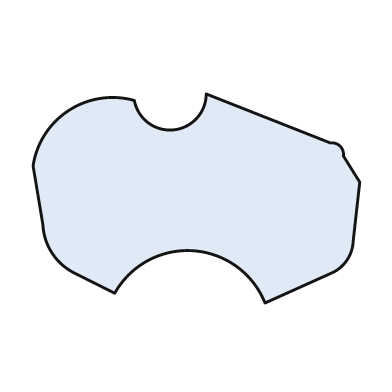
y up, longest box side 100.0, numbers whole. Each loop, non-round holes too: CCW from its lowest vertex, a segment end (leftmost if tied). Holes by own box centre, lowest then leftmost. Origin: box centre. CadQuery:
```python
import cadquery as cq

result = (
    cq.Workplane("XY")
    .moveTo(21.0, -32.0)
    .lineTo(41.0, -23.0)
    .threePointArc((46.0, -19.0), (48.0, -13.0))
    .lineTo(50.0, 5.0)
    .lineTo(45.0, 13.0)
    .threePointArc((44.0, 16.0), (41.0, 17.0))
    .lineTo(3.0, 32.0)
    .threePointArc((-7.0, 21.0), (-19.0, 30.0))
    .threePointArc((-39.0, 27.0), (-50.0, 10.0))
    .lineTo(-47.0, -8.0)
    .threePointArc((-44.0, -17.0), (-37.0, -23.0))
    .lineTo(-25.0, -29.0)
    .threePointArc((-1.0, -16.0), (21.0, -32.0))
    .close()
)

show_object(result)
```